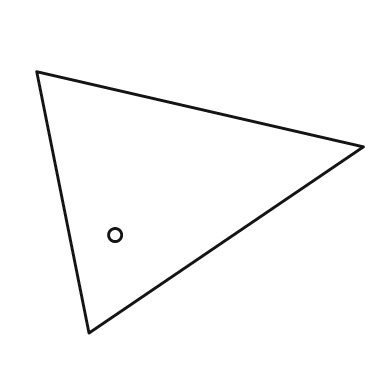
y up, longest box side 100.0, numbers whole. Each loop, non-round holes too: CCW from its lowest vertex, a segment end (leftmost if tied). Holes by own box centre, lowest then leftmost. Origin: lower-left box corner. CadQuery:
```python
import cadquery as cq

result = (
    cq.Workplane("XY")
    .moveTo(16.0, 0.0)
    .lineTo(100.0, 57.0)
    .lineTo(0.0, 80.0)
    .close()
    .moveTo(24.0, 30.0)
    .circle(2.0)
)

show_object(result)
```